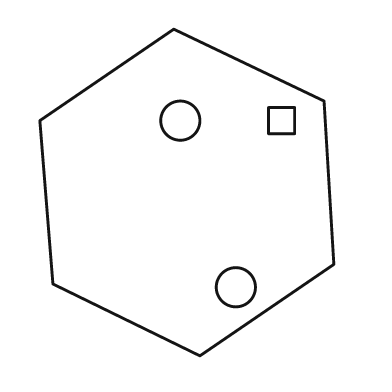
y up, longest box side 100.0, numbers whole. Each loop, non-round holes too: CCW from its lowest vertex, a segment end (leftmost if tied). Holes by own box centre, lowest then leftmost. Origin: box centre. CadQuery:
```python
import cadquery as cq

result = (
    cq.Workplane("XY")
    .moveTo(4.0, -50.0)
    .lineTo(45.0, -22.0)
    .lineTo(42.0, 28.0)
    .lineTo(-4.0, 50.0)
    .lineTo(-45.0, 22.0)
    .lineTo(-41.0, -28.0)
    .close()
    .moveTo(15.0, -29.0)
    .circle(6.0)
    .moveTo(-2.0, 22.0)
    .circle(6.0)
    .moveTo(25.0, 18.0)
    .lineTo(33.0, 18.0)
    .lineTo(33.0, 26.0)
    .lineTo(25.0, 26.0)
    .close()
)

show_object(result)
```